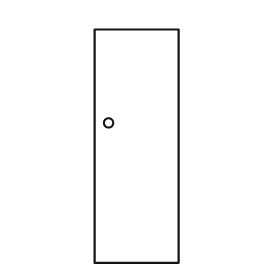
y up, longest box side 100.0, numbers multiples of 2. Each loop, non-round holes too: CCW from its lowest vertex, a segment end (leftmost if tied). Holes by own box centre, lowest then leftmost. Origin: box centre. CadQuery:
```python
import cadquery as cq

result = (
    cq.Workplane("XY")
    .moveTo(-18.0, -50.0)
    .lineTo(18.0, -50.0)
    .lineTo(18.0, 50.0)
    .lineTo(-18.0, 50.0)
    .close()
    .moveTo(-12.0, 10.0)
    .circle(2.0)
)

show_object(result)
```